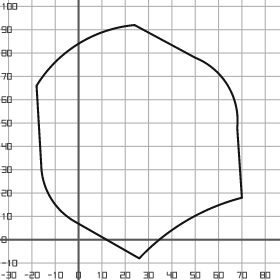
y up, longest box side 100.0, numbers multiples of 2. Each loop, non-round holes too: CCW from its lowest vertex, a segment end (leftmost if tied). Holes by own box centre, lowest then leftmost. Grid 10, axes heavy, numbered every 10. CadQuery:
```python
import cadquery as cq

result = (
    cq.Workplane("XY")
    .moveTo(26.0, -8.0)
    .threePointArc((46.0, 8.0), (70.0, 18.0))
    .lineTo(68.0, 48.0)
    .threePointArc((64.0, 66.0), (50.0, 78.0))
    .lineTo(24.0, 92.0)
    .threePointArc((0.0, 84.0), (-18.0, 66.0))
    .lineTo(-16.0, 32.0)
    .threePointArc((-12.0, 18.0), (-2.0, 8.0))
    .close()
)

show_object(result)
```